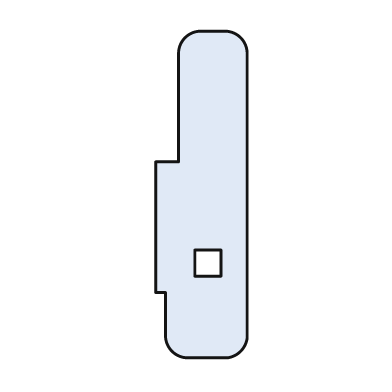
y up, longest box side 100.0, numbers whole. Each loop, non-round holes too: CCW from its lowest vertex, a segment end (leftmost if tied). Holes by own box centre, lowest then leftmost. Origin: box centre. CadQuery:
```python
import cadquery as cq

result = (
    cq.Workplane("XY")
    .moveTo(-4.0, -50.0)
    .lineTo(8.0, -50.0)
    .threePointArc((12.0, -48.0), (14.0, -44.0))
    .lineTo(14.0, 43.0)
    .threePointArc((12.0, 48.0), (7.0, 50.0))
    .lineTo(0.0, 50.0)
    .threePointArc((-5.0, 48.0), (-7.0, 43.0))
    .lineTo(-7.0, 10.0)
    .lineTo(-14.0, 10.0)
    .lineTo(-14.0, -30.0)
    .lineTo(-11.0, -30.0)
    .lineTo(-11.0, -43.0)
    .threePointArc((-9.0, -48.0), (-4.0, -50.0))
    .close()
    .moveTo(-2.0, -25.0)
    .lineTo(6.0, -25.0)
    .lineTo(6.0, -17.0)
    .lineTo(-2.0, -17.0)
    .close()
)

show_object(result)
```